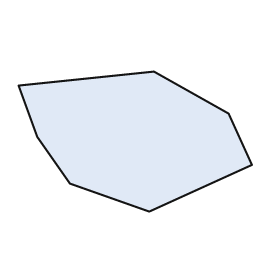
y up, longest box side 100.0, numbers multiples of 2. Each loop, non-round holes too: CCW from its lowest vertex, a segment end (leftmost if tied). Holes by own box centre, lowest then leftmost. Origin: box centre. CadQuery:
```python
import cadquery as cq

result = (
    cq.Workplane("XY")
    .moveTo(6.0, -30.0)
    .lineTo(50.0, -10.0)
    .lineTo(40.0, 12.0)
    .lineTo(8.0, 30.0)
    .lineTo(-50.0, 24.0)
    .lineTo(-42.0, 2.0)
    .lineTo(-28.0, -18.0)
    .close()
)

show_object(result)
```